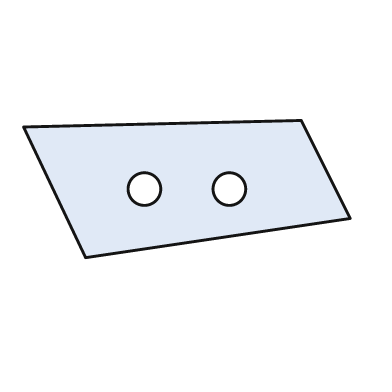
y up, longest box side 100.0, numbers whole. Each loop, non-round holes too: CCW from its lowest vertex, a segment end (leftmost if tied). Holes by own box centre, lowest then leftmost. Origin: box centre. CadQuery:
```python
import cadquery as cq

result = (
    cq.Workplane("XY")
    .moveTo(-31.0, -21.0)
    .lineTo(50.0, -9.0)
    .lineTo(35.0, 21.0)
    .lineTo(-50.0, 19.0)
    .close()
    .moveTo(-13.0, 0.0)
    .circle(5.0)
    .moveTo(13.0, 0.0)
    .circle(5.0)
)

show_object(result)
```